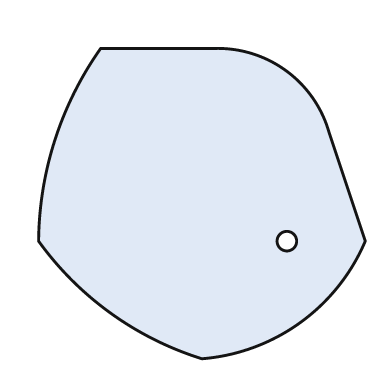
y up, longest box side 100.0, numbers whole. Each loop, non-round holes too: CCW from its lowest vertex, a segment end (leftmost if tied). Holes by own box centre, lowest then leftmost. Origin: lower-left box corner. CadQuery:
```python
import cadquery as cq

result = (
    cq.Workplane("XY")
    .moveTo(50.0, 0.0)
    .threePointArc((80.0, 11.0), (100.0, 36.0))
    .lineTo(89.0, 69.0)
    .threePointArc((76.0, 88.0), (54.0, 95.0))
    .lineTo(19.0, 95.0)
    .threePointArc((5.0, 67.0), (0.0, 36.0))
    .threePointArc((22.0, 14.0), (50.0, 0.0))
    .close()
    .moveTo(76.0, 36.0)
    .circle(3.0)
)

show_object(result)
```